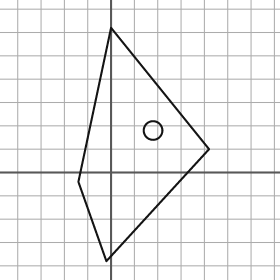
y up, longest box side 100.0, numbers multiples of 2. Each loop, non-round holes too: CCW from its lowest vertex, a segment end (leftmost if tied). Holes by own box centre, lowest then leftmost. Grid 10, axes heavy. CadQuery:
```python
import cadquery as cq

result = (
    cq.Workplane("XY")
    .moveTo(-2.0, -38.0)
    .lineTo(42.0, 10.0)
    .lineTo(0.0, 62.0)
    .lineTo(-14.0, -4.0)
    .close()
    .moveTo(18.0, 18.0)
    .circle(4.0)
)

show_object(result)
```